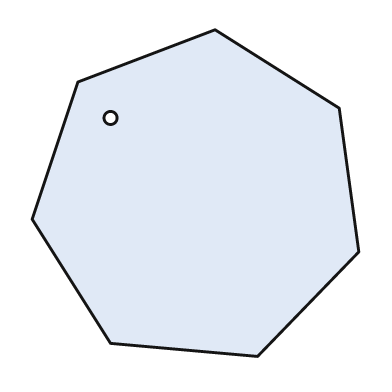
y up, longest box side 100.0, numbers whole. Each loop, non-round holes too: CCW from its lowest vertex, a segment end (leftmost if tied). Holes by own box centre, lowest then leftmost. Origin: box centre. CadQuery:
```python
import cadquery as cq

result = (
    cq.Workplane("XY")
    .moveTo(19.0, -50.0)
    .lineTo(50.0, -18.0)
    .lineTo(44.0, 26.0)
    .lineTo(6.0, 50.0)
    .lineTo(-36.0, 34.0)
    .lineTo(-50.0, -8.0)
    .lineTo(-26.0, -46.0)
    .close()
    .moveTo(-26.0, 23.0)
    .circle(2.0)
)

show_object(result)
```